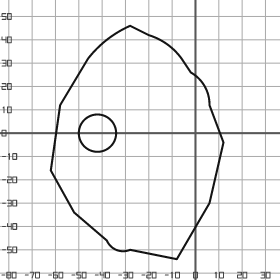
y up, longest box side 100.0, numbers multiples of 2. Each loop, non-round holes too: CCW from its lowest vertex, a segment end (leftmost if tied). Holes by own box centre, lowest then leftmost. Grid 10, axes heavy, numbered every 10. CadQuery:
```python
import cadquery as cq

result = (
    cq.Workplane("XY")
    .moveTo(-8.0, -54.0)
    .lineTo(6.0, -30.0)
    .lineTo(12.0, -4.0)
    .lineTo(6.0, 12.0)
    .threePointArc((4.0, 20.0), (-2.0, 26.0))
    .lineTo(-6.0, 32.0)
    .threePointArc((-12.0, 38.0), (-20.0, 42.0))
    .lineTo(-28.0, 46.0)
    .threePointArc((-38.0, 40.0), (-46.0, 32.0))
    .lineTo(-58.0, 12.0)
    .lineTo(-62.0, -16.0)
    .lineTo(-52.0, -34.0)
    .lineTo(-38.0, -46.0)
    .threePointArc((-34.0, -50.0), (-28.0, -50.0))
    .close()
    .moveTo(-42.0, 0.0)
    .circle(8.0)
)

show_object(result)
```